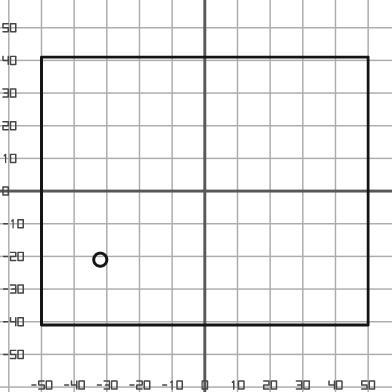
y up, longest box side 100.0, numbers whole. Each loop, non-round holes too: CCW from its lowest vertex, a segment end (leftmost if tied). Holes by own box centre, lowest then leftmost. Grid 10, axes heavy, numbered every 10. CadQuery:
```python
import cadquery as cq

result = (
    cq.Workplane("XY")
    .moveTo(-50.0, -41.0)
    .lineTo(50.0, -41.0)
    .lineTo(50.0, 41.0)
    .lineTo(-50.0, 41.0)
    .close()
    .moveTo(-32.0, -21.0)
    .circle(2.0)
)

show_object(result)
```